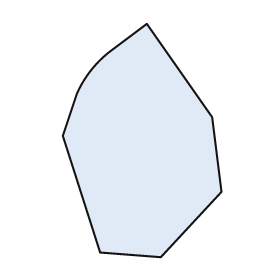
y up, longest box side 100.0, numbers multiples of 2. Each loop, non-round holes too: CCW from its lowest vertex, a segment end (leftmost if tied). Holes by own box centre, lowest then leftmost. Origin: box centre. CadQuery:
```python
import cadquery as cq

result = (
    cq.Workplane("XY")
    .moveTo(8.0, -50.0)
    .lineTo(34.0, -22.0)
    .lineTo(30.0, 10.0)
    .lineTo(2.0, 50.0)
    .lineTo(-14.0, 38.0)
    .threePointArc((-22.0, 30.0), (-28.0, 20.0))
    .lineTo(-34.0, 2.0)
    .lineTo(-18.0, -48.0)
    .close()
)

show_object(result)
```